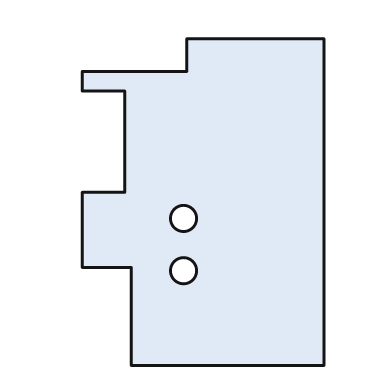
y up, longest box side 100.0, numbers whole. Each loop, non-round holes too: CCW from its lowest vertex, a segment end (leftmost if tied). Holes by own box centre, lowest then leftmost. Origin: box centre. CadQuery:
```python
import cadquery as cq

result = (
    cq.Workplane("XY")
    .moveTo(-22.0, -50.0)
    .lineTo(37.0, -50.0)
    .lineTo(37.0, 50.0)
    .lineTo(-5.0, 50.0)
    .lineTo(-5.0, 40.0)
    .lineTo(-37.0, 40.0)
    .lineTo(-37.0, 34.0)
    .lineTo(-24.0, 34.0)
    .lineTo(-24.0, 3.0)
    .lineTo(-37.0, 3.0)
    .lineTo(-37.0, -20.0)
    .lineTo(-22.0, -20.0)
    .close()
    .moveTo(-6.0, -21.0)
    .circle(4.0)
    .moveTo(-6.0, -5.0)
    .circle(4.0)
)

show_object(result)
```